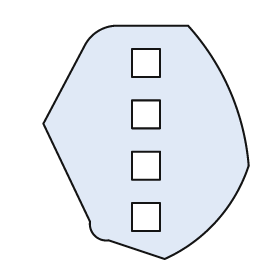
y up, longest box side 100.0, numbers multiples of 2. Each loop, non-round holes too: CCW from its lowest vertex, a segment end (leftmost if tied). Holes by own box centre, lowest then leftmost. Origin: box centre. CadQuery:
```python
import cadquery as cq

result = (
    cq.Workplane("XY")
    .moveTo(8.0, -50.0)
    .threePointArc((30.0, -34.0), (44.0, -10.0))
    .threePointArc((36.0, 22.0), (18.0, 50.0))
    .lineTo(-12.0, 50.0)
    .threePointArc((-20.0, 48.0), (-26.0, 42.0))
    .lineTo(-44.0, 8.0)
    .lineTo(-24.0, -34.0)
    .threePointArc((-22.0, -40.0), (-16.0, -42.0))
    .close()
    .moveTo(-6.0, -38.0)
    .lineTo(6.0, -38.0)
    .lineTo(6.0, -26.0)
    .lineTo(-6.0, -26.0)
    .close()
    .moveTo(-6.0, -16.0)
    .lineTo(6.0, -16.0)
    .lineTo(6.0, -4.0)
    .lineTo(-6.0, -4.0)
    .close()
    .moveTo(-6.0, 6.0)
    .lineTo(6.0, 6.0)
    .lineTo(6.0, 18.0)
    .lineTo(-6.0, 18.0)
    .close()
    .moveTo(-6.0, 28.0)
    .lineTo(6.0, 28.0)
    .lineTo(6.0, 40.0)
    .lineTo(-6.0, 40.0)
    .close()
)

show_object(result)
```